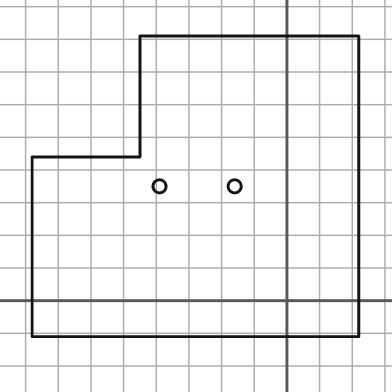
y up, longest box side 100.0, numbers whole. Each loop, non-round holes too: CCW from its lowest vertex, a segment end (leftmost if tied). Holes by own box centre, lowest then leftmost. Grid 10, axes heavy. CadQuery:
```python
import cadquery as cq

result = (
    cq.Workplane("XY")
    .moveTo(-78.0, -11.0)
    .lineTo(22.0, -11.0)
    .lineTo(22.0, 81.0)
    .lineTo(-45.0, 81.0)
    .lineTo(-45.0, 44.0)
    .lineTo(-78.0, 44.0)
    .close()
    .moveTo(-39.0, 35.0)
    .circle(2.0)
    .moveTo(-16.0, 35.0)
    .circle(2.0)
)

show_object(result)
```